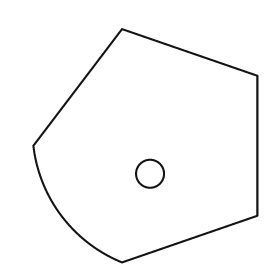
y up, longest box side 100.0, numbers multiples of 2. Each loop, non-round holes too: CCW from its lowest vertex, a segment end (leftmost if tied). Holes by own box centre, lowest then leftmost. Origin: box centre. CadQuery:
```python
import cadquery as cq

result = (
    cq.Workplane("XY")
    .moveTo(-10.0, -50.0)
    .lineTo(48.0, -30.0)
    .lineTo(48.0, 30.0)
    .lineTo(-10.0, 50.0)
    .lineTo(-48.0, 0.0)
    .threePointArc((-36.0, -30.0), (-10.0, -50.0))
    .close()
    .moveTo(2.0, -12.0)
    .circle(6.0)
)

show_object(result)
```